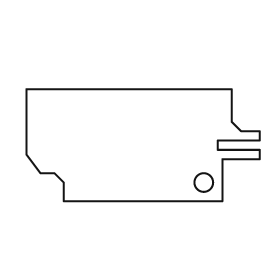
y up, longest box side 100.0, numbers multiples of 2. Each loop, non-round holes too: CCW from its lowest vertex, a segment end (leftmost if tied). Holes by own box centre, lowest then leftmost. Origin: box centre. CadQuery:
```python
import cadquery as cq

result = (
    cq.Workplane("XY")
    .moveTo(-34.0, -24.0)
    .lineTo(34.0, -24.0)
    .lineTo(34.0, -6.0)
    .lineTo(50.0, -6.0)
    .lineTo(50.0, -2.0)
    .lineTo(32.0, -2.0)
    .lineTo(32.0, 2.0)
    .lineTo(50.0, 2.0)
    .lineTo(50.0, 6.0)
    .lineTo(42.0, 6.0)
    .lineTo(38.0, 10.0)
    .lineTo(38.0, 24.0)
    .lineTo(-50.0, 24.0)
    .lineTo(-50.0, -4.0)
    .lineTo(-44.0, -12.0)
    .lineTo(-38.0, -12.0)
    .lineTo(-34.0, -16.0)
    .close()
    .moveTo(26.0, -16.0)
    .circle(4.0)
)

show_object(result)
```